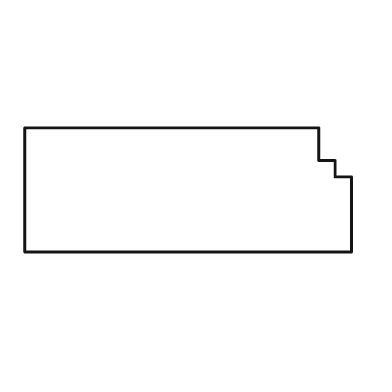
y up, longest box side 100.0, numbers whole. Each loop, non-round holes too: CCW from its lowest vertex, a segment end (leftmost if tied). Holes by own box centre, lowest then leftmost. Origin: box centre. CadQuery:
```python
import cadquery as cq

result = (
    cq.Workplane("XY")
    .moveTo(-50.0, -19.0)
    .lineTo(50.0, -19.0)
    .lineTo(50.0, 4.0)
    .lineTo(45.0, 4.0)
    .lineTo(45.0, 9.0)
    .lineTo(40.0, 9.0)
    .lineTo(40.0, 19.0)
    .lineTo(-50.0, 19.0)
    .close()
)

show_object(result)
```